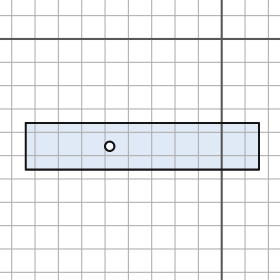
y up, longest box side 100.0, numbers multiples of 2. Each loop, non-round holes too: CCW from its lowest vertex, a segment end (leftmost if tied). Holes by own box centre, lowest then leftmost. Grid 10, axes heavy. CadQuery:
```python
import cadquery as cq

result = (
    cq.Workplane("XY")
    .moveTo(-84.0, -56.0)
    .lineTo(16.0, -56.0)
    .lineTo(16.0, -36.0)
    .lineTo(-84.0, -36.0)
    .close()
    .moveTo(-48.0, -46.0)
    .circle(2.0)
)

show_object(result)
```